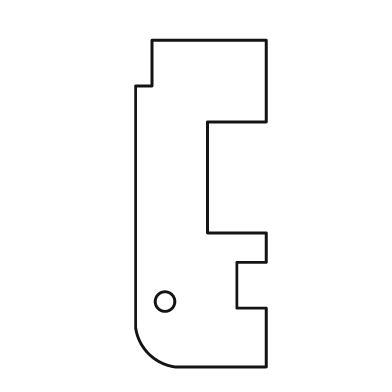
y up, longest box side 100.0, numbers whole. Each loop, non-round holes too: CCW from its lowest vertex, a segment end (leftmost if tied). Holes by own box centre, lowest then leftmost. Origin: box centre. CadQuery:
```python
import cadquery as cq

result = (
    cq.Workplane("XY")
    .moveTo(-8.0, -50.0)
    .lineTo(20.0, -50.0)
    .lineTo(20.0, -32.0)
    .lineTo(11.0, -32.0)
    .lineTo(11.0, -18.0)
    .lineTo(20.0, -18.0)
    .lineTo(20.0, -9.0)
    .lineTo(2.0, -9.0)
    .lineTo(2.0, 25.0)
    .lineTo(20.0, 25.0)
    .lineTo(20.0, 50.0)
    .lineTo(-15.0, 50.0)
    .lineTo(-15.0, 36.0)
    .lineTo(-20.0, 36.0)
    .lineTo(-20.0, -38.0)
    .threePointArc((-16.0, -46.0), (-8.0, -50.0))
    .close()
    .moveTo(-11.0, -30.0)
    .circle(3.0)
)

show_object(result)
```